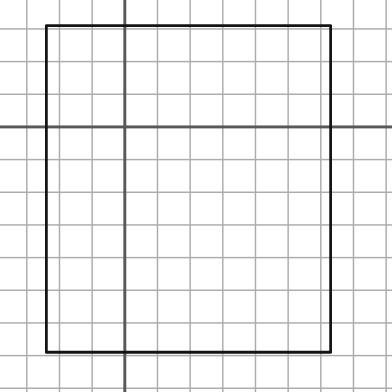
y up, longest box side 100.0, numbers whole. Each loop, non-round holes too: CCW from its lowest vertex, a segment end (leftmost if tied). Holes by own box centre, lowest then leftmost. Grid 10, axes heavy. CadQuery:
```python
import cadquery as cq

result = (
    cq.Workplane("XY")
    .moveTo(-24.0, -69.0)
    .lineTo(63.0, -69.0)
    .lineTo(63.0, 31.0)
    .lineTo(-24.0, 31.0)
    .close()
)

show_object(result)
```